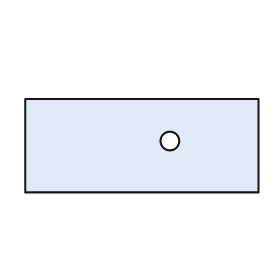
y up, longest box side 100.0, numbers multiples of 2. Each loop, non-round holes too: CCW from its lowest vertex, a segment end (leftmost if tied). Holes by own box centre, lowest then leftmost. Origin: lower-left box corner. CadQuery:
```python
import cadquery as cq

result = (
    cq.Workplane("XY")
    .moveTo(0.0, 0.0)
    .lineTo(100.0, 0.0)
    .lineTo(100.0, 40.0)
    .lineTo(0.0, 40.0)
    .close()
    .moveTo(62.0, 22.0)
    .circle(4.0)
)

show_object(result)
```